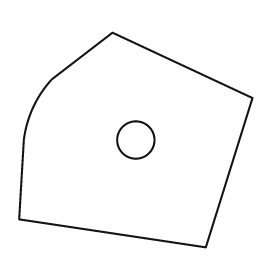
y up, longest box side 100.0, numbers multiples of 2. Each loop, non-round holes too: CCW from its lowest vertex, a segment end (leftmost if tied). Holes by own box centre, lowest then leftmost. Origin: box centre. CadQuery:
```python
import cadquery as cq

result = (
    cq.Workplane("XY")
    .moveTo(30.0, -46.0)
    .lineTo(50.0, 18.0)
    .lineTo(-10.0, 46.0)
    .lineTo(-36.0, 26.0)
    .threePointArc((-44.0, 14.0), (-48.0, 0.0))
    .lineTo(-50.0, -34.0)
    .close()
    .moveTo(0.0, 0.0)
    .circle(8.0)
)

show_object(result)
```